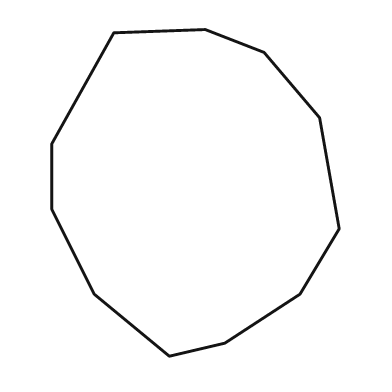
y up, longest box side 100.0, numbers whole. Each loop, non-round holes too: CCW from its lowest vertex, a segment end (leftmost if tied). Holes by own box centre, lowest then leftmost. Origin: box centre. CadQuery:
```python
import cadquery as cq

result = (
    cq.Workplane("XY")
    .moveTo(-8.0, -50.0)
    .lineTo(9.0, -46.0)
    .lineTo(32.0, -31.0)
    .lineTo(44.0, -11.0)
    .lineTo(38.0, 23.0)
    .lineTo(21.0, 43.0)
    .lineTo(3.0, 50.0)
    .lineTo(-25.0, 49.0)
    .lineTo(-44.0, 15.0)
    .lineTo(-44.0, -5.0)
    .lineTo(-31.0, -31.0)
    .close()
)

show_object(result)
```